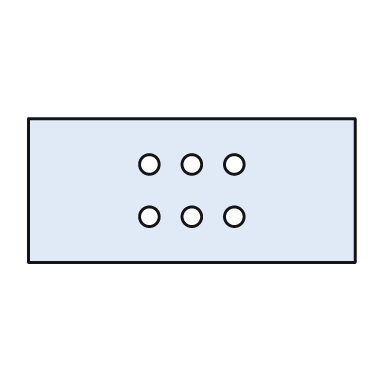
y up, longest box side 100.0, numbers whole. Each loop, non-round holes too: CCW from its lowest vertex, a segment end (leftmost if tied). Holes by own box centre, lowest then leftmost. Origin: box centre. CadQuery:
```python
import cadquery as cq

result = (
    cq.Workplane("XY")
    .moveTo(-50.0, -22.0)
    .lineTo(50.0, -22.0)
    .lineTo(50.0, 22.0)
    .lineTo(-50.0, 22.0)
    .close()
    .moveTo(-13.0, -8.0)
    .circle(3.0)
    .moveTo(0.0, -8.0)
    .circle(3.0)
    .moveTo(13.0, -8.0)
    .circle(3.0)
    .moveTo(-13.0, 8.0)
    .circle(3.0)
    .moveTo(0.0, 8.0)
    .circle(3.0)
    .moveTo(13.0, 8.0)
    .circle(3.0)
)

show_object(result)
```